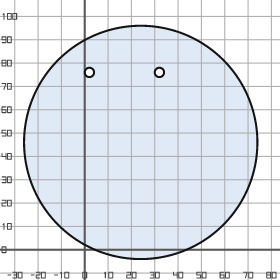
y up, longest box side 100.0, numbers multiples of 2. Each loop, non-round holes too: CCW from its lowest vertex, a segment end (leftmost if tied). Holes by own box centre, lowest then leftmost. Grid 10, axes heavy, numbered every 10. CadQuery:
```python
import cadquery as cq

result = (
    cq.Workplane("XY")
    .moveTo(24.0, 46.0)
    .circle(50.0)
    .moveTo(2.0, 76.0)
    .circle(2.0)
    .moveTo(32.0, 76.0)
    .circle(2.0)
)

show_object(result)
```